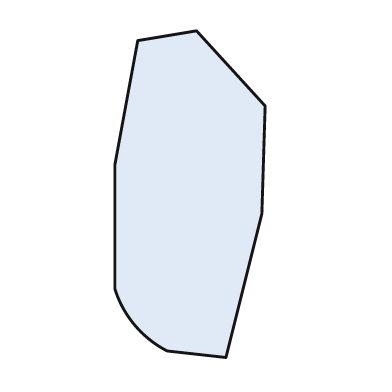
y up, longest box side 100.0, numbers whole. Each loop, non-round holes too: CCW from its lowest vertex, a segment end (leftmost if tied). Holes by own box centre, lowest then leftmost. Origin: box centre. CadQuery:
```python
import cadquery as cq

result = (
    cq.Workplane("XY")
    .moveTo(11.0, -50.0)
    .lineTo(22.0, -6.0)
    .lineTo(23.0, 27.0)
    .lineTo(2.0, 50.0)
    .lineTo(-16.0, 47.0)
    .lineTo(-23.0, 9.0)
    .lineTo(-23.0, -29.0)
    .threePointArc((-17.0, -40.0), (-7.0, -48.0))
    .close()
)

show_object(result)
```